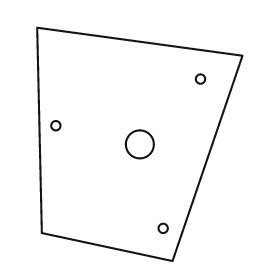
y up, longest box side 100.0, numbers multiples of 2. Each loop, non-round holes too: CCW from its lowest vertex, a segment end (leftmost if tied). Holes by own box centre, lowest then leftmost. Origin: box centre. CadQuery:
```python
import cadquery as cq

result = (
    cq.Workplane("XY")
    .moveTo(14.0, -50.0)
    .lineTo(44.0, 38.0)
    .lineTo(-44.0, 50.0)
    .lineTo(-42.0, -38.0)
    .close()
    .moveTo(10.0, -36.0)
    .circle(2.0)
    .moveTo(0.0, 0.0)
    .circle(6.0)
    .moveTo(-36.0, 8.0)
    .circle(2.0)
    .moveTo(26.0, 28.0)
    .circle(2.0)
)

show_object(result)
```